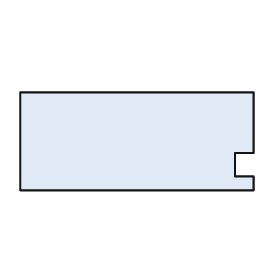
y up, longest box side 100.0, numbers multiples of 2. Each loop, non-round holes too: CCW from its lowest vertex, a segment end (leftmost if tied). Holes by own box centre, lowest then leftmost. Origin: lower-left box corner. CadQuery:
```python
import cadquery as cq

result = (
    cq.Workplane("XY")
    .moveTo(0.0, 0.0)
    .lineTo(100.0, 0.0)
    .lineTo(100.0, 6.0)
    .lineTo(92.0, 6.0)
    .lineTo(92.0, 16.0)
    .lineTo(100.0, 16.0)
    .lineTo(100.0, 42.0)
    .lineTo(0.0, 42.0)
    .close()
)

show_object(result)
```